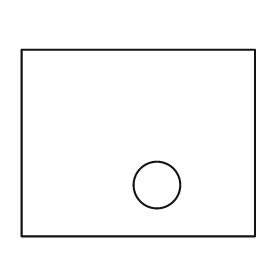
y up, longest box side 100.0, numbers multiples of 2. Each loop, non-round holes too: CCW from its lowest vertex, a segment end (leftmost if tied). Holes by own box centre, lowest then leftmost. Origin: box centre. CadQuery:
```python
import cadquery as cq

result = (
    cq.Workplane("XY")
    .moveTo(-50.0, -40.0)
    .lineTo(50.0, -40.0)
    .lineTo(50.0, 40.0)
    .lineTo(-50.0, 40.0)
    .close()
    .moveTo(8.0, -18.0)
    .circle(10.0)
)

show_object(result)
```